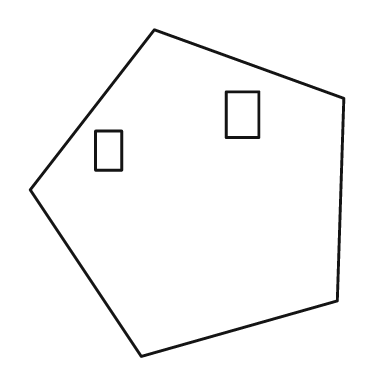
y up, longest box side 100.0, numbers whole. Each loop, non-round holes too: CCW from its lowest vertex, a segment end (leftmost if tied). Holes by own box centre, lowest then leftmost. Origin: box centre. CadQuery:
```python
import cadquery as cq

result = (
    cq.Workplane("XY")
    .moveTo(-14.0, -50.0)
    .lineTo(46.0, -33.0)
    .lineTo(48.0, 29.0)
    .lineTo(-10.0, 50.0)
    .lineTo(-48.0, 1.0)
    .close()
    .moveTo(-28.0, 7.0)
    .lineTo(-20.0, 7.0)
    .lineTo(-20.0, 19.0)
    .lineTo(-28.0, 19.0)
    .close()
    .moveTo(12.0, 17.0)
    .lineTo(22.0, 17.0)
    .lineTo(22.0, 31.0)
    .lineTo(12.0, 31.0)
    .close()
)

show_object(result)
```